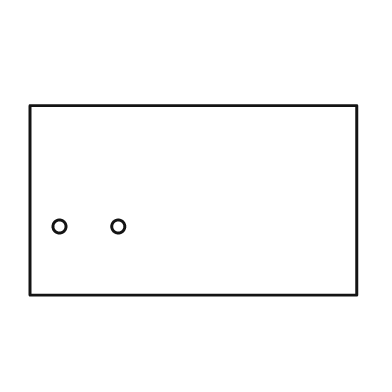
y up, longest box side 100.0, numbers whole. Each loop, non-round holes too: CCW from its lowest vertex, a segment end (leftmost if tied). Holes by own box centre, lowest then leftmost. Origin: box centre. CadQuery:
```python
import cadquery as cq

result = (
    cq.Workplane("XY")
    .moveTo(-50.0, -29.0)
    .lineTo(50.0, -29.0)
    .lineTo(50.0, 29.0)
    .lineTo(-50.0, 29.0)
    .close()
    .moveTo(-41.0, -8.0)
    .circle(2.0)
    .moveTo(-23.0, -8.0)
    .circle(2.0)
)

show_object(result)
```